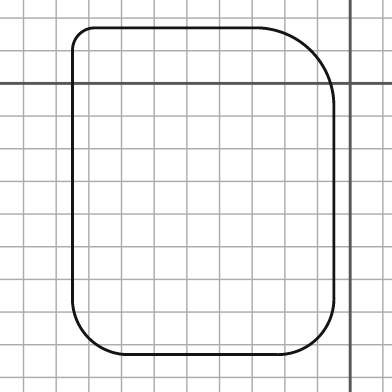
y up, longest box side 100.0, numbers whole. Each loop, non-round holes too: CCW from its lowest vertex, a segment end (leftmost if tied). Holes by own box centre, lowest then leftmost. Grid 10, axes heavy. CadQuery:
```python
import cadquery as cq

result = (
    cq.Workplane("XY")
    .moveTo(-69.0, -83.0)
    .lineTo(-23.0, -83.0)
    .threePointArc((-10.0, -78.0), (-5.0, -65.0))
    .lineTo(-5.0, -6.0)
    .threePointArc((-12.0, 10.0), (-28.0, 17.0))
    .lineTo(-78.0, 17.0)
    .threePointArc((-83.0, 15.0), (-85.0, 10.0))
    .lineTo(-85.0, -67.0)
    .threePointArc((-80.0, -78.0), (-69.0, -83.0))
    .close()
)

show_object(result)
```